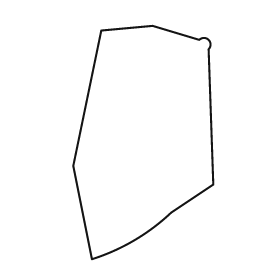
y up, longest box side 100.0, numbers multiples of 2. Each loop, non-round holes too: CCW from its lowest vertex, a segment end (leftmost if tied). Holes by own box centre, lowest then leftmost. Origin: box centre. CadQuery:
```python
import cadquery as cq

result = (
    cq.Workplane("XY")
    .moveTo(-22.0, -50.0)
    .threePointArc((-4.0, -42.0), (12.0, -30.0))
    .lineTo(30.0, -18.0)
    .lineTo(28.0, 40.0)
    .threePointArc((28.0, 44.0), (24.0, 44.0))
    .lineTo(4.0, 50.0)
    .lineTo(-18.0, 48.0)
    .lineTo(-30.0, -10.0)
    .close()
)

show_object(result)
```